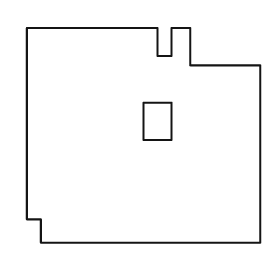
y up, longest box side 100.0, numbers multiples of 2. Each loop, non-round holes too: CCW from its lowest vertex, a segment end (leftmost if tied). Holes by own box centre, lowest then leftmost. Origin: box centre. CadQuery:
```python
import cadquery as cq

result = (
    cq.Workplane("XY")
    .moveTo(-44.0, -46.0)
    .lineTo(50.0, -46.0)
    .lineTo(50.0, 30.0)
    .lineTo(20.0, 30.0)
    .lineTo(20.0, 46.0)
    .lineTo(12.0, 46.0)
    .lineTo(12.0, 34.0)
    .lineTo(6.0, 34.0)
    .lineTo(6.0, 46.0)
    .lineTo(-50.0, 46.0)
    .lineTo(-50.0, -36.0)
    .lineTo(-44.0, -36.0)
    .close()
    .moveTo(0.0, -2.0)
    .lineTo(12.0, -2.0)
    .lineTo(12.0, 14.0)
    .lineTo(0.0, 14.0)
    .close()
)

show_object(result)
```